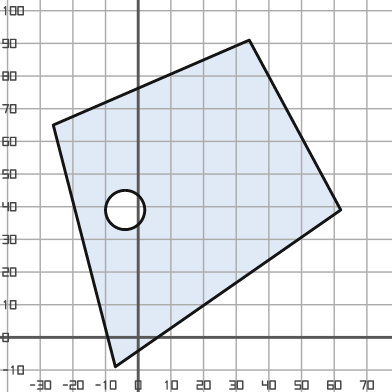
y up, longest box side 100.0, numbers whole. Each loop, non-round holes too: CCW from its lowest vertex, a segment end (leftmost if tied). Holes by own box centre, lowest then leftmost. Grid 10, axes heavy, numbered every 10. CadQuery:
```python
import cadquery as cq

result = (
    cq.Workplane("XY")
    .moveTo(-7.0, -9.0)
    .lineTo(62.0, 39.0)
    .lineTo(34.0, 91.0)
    .lineTo(-26.0, 65.0)
    .close()
    .moveTo(-4.0, 39.0)
    .circle(6.0)
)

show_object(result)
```